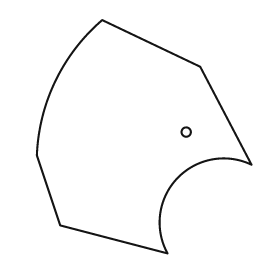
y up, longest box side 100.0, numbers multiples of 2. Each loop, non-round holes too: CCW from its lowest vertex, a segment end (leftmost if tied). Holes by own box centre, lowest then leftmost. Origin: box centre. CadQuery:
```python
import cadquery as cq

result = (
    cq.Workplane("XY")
    .moveTo(10.0, -50.0)
    .threePointArc((14.0, -18.0), (46.0, -12.0))
    .lineTo(24.0, 30.0)
    .lineTo(-18.0, 50.0)
    .threePointArc((-38.0, 24.0), (-46.0, -8.0))
    .lineTo(-36.0, -38.0)
    .close()
    .moveTo(18.0, 2.0)
    .circle(2.0)
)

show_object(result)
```